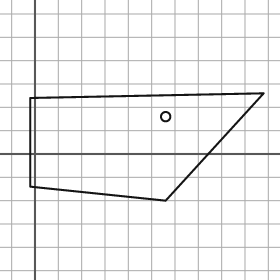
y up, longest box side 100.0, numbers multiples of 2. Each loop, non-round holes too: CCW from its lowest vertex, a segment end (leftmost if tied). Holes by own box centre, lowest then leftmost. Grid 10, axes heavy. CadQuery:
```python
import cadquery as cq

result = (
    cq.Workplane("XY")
    .moveTo(56.0, -20.0)
    .lineTo(98.0, 26.0)
    .lineTo(-2.0, 24.0)
    .lineTo(-2.0, -14.0)
    .close()
    .moveTo(56.0, 16.0)
    .circle(2.0)
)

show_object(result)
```